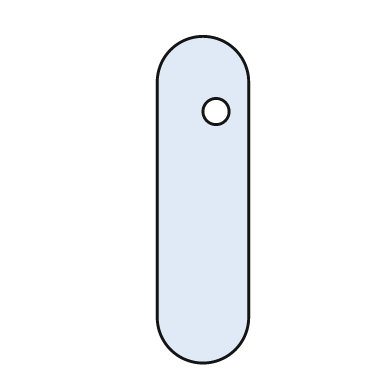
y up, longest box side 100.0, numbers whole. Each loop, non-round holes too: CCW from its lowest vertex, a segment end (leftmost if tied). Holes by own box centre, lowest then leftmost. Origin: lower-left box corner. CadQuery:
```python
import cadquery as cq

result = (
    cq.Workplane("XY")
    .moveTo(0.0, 14.0)
    .threePointArc((14.0, 0.0), (28.0, 14.0))
    .lineTo(28.0, 86.0)
    .threePointArc((14.0, 100.0), (0.0, 86.0))
    .close()
    .moveTo(18.0, 77.0)
    .circle(4.0)
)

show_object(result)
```